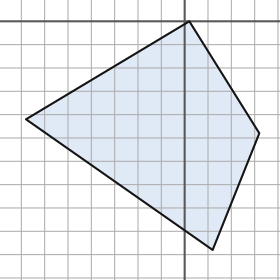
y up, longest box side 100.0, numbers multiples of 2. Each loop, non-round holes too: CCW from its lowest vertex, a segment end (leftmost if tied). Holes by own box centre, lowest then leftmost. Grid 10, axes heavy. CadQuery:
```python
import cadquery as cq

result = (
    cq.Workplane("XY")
    .moveTo(12.0, -98.0)
    .lineTo(32.0, -48.0)
    .lineTo(2.0, 0.0)
    .lineTo(-68.0, -42.0)
    .close()
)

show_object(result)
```